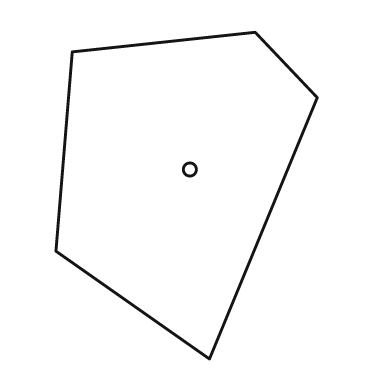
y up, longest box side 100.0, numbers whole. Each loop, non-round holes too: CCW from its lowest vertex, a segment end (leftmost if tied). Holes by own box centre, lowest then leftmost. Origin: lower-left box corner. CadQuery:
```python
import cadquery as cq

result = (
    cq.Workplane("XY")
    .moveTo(47.0, 0.0)
    .lineTo(80.0, 80.0)
    .lineTo(61.0, 100.0)
    .lineTo(5.0, 94.0)
    .lineTo(0.0, 33.0)
    .close()
    .moveTo(41.0, 58.0)
    .circle(2.0)
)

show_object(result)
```